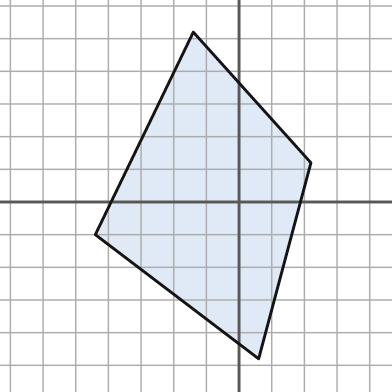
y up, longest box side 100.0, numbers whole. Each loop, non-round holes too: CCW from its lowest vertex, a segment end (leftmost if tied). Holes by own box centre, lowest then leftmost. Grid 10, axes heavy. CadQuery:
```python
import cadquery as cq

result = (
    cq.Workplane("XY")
    .moveTo(6.0, -48.0)
    .lineTo(22.0, 12.0)
    .lineTo(-14.0, 52.0)
    .lineTo(-44.0, -10.0)
    .close()
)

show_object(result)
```